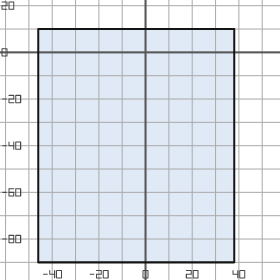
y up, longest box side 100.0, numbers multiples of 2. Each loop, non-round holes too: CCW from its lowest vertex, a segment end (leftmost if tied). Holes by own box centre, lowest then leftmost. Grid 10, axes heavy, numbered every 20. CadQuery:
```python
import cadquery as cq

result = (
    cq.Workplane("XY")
    .moveTo(-46.0, -90.0)
    .lineTo(38.0, -90.0)
    .lineTo(38.0, 10.0)
    .lineTo(-46.0, 10.0)
    .close()
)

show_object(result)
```